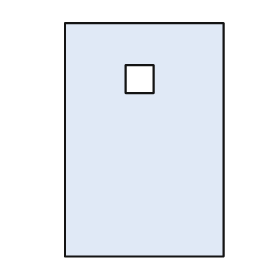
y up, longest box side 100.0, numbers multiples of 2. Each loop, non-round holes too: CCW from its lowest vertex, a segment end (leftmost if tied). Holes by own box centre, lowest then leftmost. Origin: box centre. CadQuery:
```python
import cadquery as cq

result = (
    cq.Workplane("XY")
    .moveTo(-34.0, -50.0)
    .lineTo(34.0, -50.0)
    .lineTo(34.0, 50.0)
    .lineTo(-34.0, 50.0)
    .close()
    .moveTo(-8.0, 20.0)
    .lineTo(4.0, 20.0)
    .lineTo(4.0, 32.0)
    .lineTo(-8.0, 32.0)
    .close()
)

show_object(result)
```